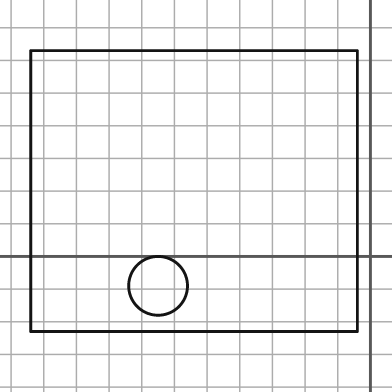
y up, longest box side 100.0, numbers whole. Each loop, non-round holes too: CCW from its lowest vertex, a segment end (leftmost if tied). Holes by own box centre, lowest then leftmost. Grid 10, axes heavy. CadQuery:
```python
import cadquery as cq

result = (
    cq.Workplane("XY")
    .moveTo(-104.0, -23.0)
    .lineTo(-4.0, -23.0)
    .lineTo(-4.0, 63.0)
    .lineTo(-104.0, 63.0)
    .close()
    .moveTo(-65.0, -9.0)
    .circle(9.0)
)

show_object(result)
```